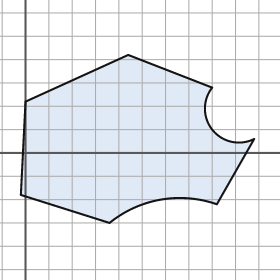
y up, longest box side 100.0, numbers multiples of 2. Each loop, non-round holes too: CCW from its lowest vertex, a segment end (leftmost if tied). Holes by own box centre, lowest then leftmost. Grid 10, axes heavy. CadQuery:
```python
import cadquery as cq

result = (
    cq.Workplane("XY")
    .moveTo(36.0, -30.0)
    .threePointArc((58.0, -20.0), (82.0, -22.0))
    .lineTo(98.0, 6.0)
    .threePointArc((80.0, 10.0), (80.0, 28.0))
    .lineTo(44.0, 42.0)
    .lineTo(0.0, 22.0)
    .lineTo(-2.0, -18.0)
    .close()
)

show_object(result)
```